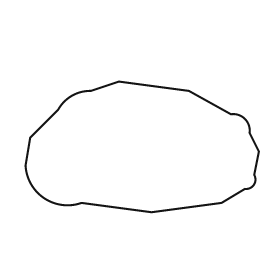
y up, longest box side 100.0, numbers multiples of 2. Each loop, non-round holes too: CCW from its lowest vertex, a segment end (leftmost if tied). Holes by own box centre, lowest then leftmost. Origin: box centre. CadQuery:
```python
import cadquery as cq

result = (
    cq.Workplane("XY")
    .moveTo(4.0, -28.0)
    .lineTo(34.0, -24.0)
    .lineTo(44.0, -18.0)
    .threePointArc((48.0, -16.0), (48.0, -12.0))
    .lineTo(50.0, -2.0)
    .lineTo(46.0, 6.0)
    .threePointArc((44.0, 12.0), (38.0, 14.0))
    .lineTo(20.0, 24.0)
    .lineTo(-10.0, 28.0)
    .lineTo(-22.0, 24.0)
    .threePointArc((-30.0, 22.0), (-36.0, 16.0))
    .lineTo(-48.0, 4.0)
    .lineTo(-50.0, -8.0)
    .threePointArc((-42.0, -22.0), (-26.0, -24.0))
    .close()
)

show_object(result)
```